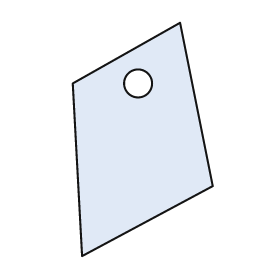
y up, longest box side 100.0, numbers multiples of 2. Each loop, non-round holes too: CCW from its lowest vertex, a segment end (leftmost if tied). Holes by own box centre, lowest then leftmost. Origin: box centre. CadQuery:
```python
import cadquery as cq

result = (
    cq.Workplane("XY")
    .moveTo(-26.0, -50.0)
    .lineTo(30.0, -20.0)
    .lineTo(16.0, 50.0)
    .lineTo(-30.0, 24.0)
    .close()
    .moveTo(-2.0, 24.0)
    .circle(6.0)
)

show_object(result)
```